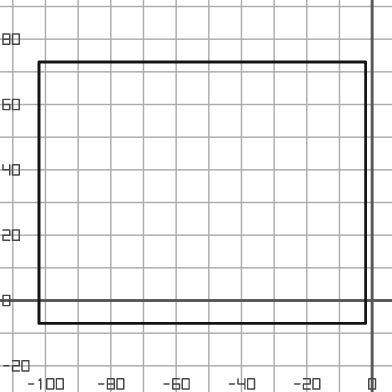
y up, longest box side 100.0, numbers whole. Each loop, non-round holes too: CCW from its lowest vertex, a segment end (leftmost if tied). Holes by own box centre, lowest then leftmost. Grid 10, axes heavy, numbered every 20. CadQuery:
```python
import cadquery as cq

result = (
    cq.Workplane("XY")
    .moveTo(-102.0, -7.0)
    .lineTo(-2.0, -7.0)
    .lineTo(-2.0, 73.0)
    .lineTo(-102.0, 73.0)
    .close()
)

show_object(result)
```